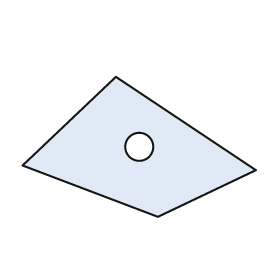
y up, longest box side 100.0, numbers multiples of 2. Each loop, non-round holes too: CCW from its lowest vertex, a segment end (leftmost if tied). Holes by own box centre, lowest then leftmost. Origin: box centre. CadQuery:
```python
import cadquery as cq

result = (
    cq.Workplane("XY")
    .moveTo(8.0, -30.0)
    .lineTo(50.0, -10.0)
    .lineTo(-10.0, 30.0)
    .lineTo(-50.0, -8.0)
    .close()
    .moveTo(0.0, 0.0)
    .circle(6.0)
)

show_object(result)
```